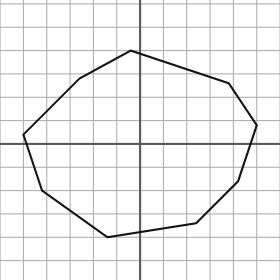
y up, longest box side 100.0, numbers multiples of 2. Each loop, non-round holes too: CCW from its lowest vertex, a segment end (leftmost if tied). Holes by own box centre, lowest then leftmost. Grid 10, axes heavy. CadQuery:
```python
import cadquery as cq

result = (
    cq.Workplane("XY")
    .moveTo(-14.0, -40.0)
    .lineTo(24.0, -34.0)
    .lineTo(42.0, -16.0)
    .lineTo(50.0, 8.0)
    .lineTo(38.0, 26.0)
    .lineTo(-4.0, 40.0)
    .lineTo(-26.0, 28.0)
    .lineTo(-50.0, 4.0)
    .lineTo(-42.0, -20.0)
    .close()
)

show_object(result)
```